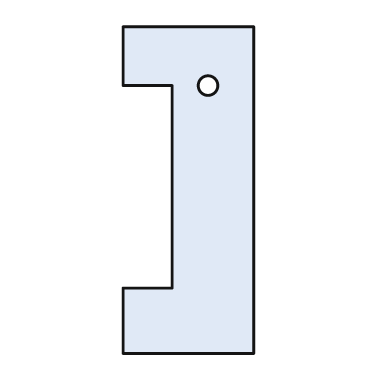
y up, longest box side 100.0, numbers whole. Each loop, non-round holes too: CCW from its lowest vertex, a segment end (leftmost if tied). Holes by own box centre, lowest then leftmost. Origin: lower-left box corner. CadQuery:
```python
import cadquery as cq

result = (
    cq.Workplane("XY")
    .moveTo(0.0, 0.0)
    .lineTo(40.0, 0.0)
    .lineTo(40.0, 100.0)
    .lineTo(0.0, 100.0)
    .lineTo(0.0, 82.0)
    .lineTo(15.0, 82.0)
    .lineTo(15.0, 20.0)
    .lineTo(0.0, 20.0)
    .close()
    .moveTo(26.0, 82.0)
    .circle(3.0)
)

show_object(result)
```